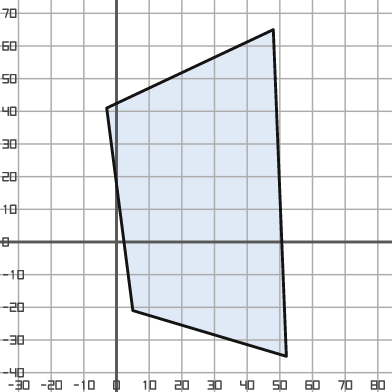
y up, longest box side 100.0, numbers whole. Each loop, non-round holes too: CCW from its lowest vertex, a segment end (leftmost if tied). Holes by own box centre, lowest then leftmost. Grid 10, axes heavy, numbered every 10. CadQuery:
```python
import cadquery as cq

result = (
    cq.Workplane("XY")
    .moveTo(52.0, -35.0)
    .lineTo(48.0, 65.0)
    .lineTo(-3.0, 41.0)
    .lineTo(5.0, -21.0)
    .close()
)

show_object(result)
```